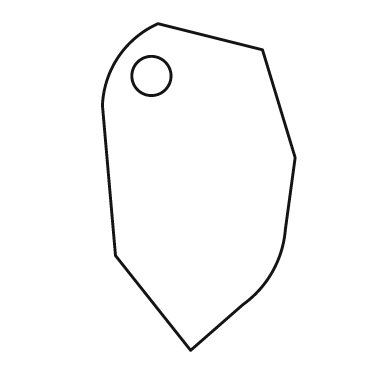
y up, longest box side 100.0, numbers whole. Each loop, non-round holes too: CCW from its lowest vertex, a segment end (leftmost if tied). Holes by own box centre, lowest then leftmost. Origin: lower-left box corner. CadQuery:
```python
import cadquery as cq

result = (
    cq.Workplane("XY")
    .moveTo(27.0, 0.0)
    .lineTo(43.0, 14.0)
    .threePointArc((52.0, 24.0), (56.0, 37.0))
    .lineTo(59.0, 59.0)
    .lineTo(49.0, 92.0)
    .lineTo(17.0, 100.0)
    .threePointArc((5.0, 90.0), (0.0, 75.0))
    .lineTo(4.0, 29.0)
    .close()
    .moveTo(15.0, 84.0)
    .circle(6.0)
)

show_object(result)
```